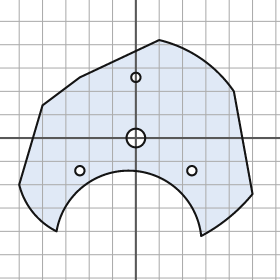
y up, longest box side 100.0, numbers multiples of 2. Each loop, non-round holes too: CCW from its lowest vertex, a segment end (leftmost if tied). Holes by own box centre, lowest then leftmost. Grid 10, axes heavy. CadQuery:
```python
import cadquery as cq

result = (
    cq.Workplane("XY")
    .moveTo(28.0, -42.0)
    .threePointArc((40.0, -34.0), (50.0, -24.0))
    .lineTo(42.0, 20.0)
    .threePointArc((28.0, 34.0), (10.0, 42.0))
    .lineTo(-24.0, 26.0)
    .lineTo(-40.0, 14.0)
    .lineTo(-50.0, -20.0)
    .threePointArc((-44.0, -32.0), (-34.0, -40.0))
    .threePointArc((-2.0, -14.0), (28.0, -42.0))
    .close()
    .moveTo(-24.0, -14.0)
    .circle(2.0)
    .moveTo(24.0, -14.0)
    .circle(2.0)
    .moveTo(0.0, 0.0)
    .circle(4.0)
    .moveTo(0.0, 26.0)
    .circle(2.0)
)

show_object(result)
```